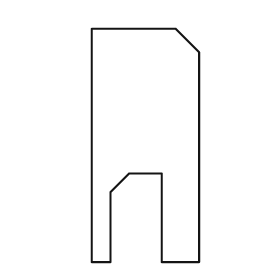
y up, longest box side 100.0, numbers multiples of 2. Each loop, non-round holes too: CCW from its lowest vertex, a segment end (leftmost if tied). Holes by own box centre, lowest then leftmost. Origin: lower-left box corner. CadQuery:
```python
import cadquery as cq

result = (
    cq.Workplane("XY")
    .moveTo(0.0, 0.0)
    .lineTo(8.0, 0.0)
    .lineTo(8.0, 30.0)
    .lineTo(16.0, 38.0)
    .lineTo(30.0, 38.0)
    .lineTo(30.0, 0.0)
    .lineTo(46.0, 0.0)
    .lineTo(46.0, 90.0)
    .lineTo(36.0, 100.0)
    .lineTo(0.0, 100.0)
    .close()
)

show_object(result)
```